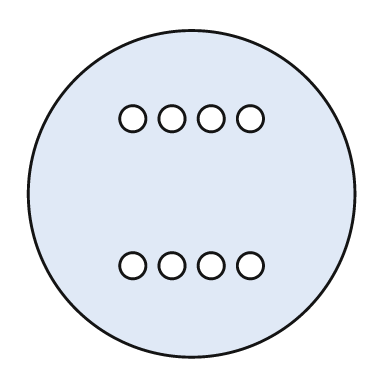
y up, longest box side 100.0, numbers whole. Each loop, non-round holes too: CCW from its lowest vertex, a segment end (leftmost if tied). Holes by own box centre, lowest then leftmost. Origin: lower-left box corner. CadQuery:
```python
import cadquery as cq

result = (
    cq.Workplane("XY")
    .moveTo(50.0, 50.0)
    .circle(50.0)
    .moveTo(32.0, 28.0)
    .circle(4.0)
    .moveTo(44.0, 28.0)
    .circle(4.0)
    .moveTo(56.0, 28.0)
    .circle(4.0)
    .moveTo(68.0, 28.0)
    .circle(4.0)
    .moveTo(32.0, 73.0)
    .circle(4.0)
    .moveTo(44.0, 73.0)
    .circle(4.0)
    .moveTo(56.0, 73.0)
    .circle(4.0)
    .moveTo(68.0, 73.0)
    .circle(4.0)
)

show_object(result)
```